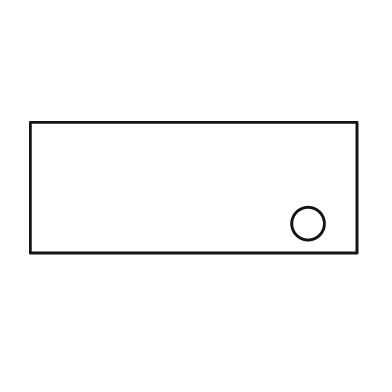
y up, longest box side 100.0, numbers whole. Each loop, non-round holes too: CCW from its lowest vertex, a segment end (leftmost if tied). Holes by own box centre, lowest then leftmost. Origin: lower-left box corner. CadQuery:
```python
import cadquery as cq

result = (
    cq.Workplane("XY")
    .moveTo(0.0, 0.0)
    .lineTo(100.0, 0.0)
    .lineTo(100.0, 40.0)
    .lineTo(0.0, 40.0)
    .close()
    .moveTo(85.0, 9.0)
    .circle(5.0)
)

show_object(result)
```